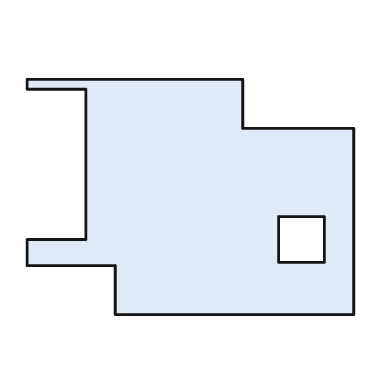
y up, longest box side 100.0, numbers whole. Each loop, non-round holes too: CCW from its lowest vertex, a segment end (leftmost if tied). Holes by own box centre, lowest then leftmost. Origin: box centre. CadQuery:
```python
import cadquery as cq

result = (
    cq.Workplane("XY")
    .moveTo(-23.0, -36.0)
    .lineTo(50.0, -36.0)
    .lineTo(50.0, 21.0)
    .lineTo(16.0, 21.0)
    .lineTo(16.0, 36.0)
    .lineTo(-50.0, 36.0)
    .lineTo(-50.0, 33.0)
    .lineTo(-32.0, 33.0)
    .lineTo(-32.0, -13.0)
    .lineTo(-50.0, -13.0)
    .lineTo(-50.0, -21.0)
    .lineTo(-23.0, -21.0)
    .close()
    .moveTo(27.0, -20.0)
    .lineTo(41.0, -20.0)
    .lineTo(41.0, -6.0)
    .lineTo(27.0, -6.0)
    .close()
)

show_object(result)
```